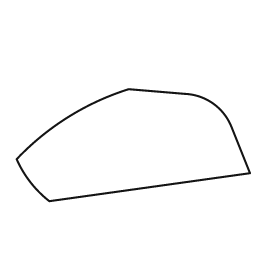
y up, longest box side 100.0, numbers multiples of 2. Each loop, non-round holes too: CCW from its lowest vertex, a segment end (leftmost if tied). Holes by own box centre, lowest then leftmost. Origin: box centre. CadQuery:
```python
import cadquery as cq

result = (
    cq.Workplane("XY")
    .moveTo(-36.0, -24.0)
    .lineTo(50.0, -12.0)
    .lineTo(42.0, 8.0)
    .threePointArc((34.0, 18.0), (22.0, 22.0))
    .lineTo(-2.0, 24.0)
    .threePointArc((-28.0, 12.0), (-50.0, -6.0))
    .threePointArc((-44.0, -16.0), (-36.0, -24.0))
    .close()
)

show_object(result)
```